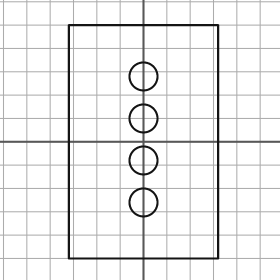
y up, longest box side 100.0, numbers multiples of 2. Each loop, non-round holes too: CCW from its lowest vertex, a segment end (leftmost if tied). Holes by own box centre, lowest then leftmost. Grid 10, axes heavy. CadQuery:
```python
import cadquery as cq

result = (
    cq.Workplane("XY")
    .moveTo(-32.0, -50.0)
    .lineTo(32.0, -50.0)
    .lineTo(32.0, 50.0)
    .lineTo(-32.0, 50.0)
    .close()
    .moveTo(0.0, -26.0)
    .circle(6.0)
    .moveTo(0.0, -8.0)
    .circle(6.0)
    .moveTo(0.0, 10.0)
    .circle(6.0)
    .moveTo(0.0, 28.0)
    .circle(6.0)
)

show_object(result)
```